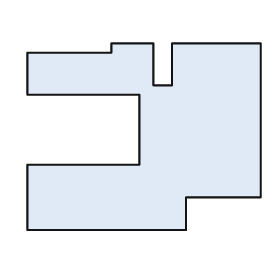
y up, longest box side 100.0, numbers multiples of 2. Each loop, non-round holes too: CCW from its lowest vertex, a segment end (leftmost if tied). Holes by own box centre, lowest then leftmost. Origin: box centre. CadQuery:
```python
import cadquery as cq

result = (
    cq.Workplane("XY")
    .moveTo(-50.0, -40.0)
    .lineTo(18.0, -40.0)
    .lineTo(18.0, -26.0)
    .lineTo(50.0, -26.0)
    .lineTo(50.0, 40.0)
    .lineTo(12.0, 40.0)
    .lineTo(12.0, 22.0)
    .lineTo(4.0, 22.0)
    .lineTo(4.0, 40.0)
    .lineTo(-14.0, 40.0)
    .lineTo(-14.0, 36.0)
    .lineTo(-50.0, 36.0)
    .lineTo(-50.0, 18.0)
    .lineTo(-2.0, 18.0)
    .lineTo(-2.0, -12.0)
    .lineTo(-50.0, -12.0)
    .close()
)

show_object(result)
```